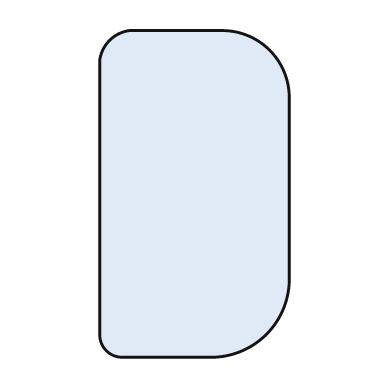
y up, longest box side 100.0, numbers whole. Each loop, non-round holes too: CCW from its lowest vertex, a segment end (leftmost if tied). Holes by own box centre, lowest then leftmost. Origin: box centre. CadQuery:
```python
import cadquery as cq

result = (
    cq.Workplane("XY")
    .moveTo(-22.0, -50.0)
    .lineTo(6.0, -50.0)
    .threePointArc((22.0, -43.0), (29.0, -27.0))
    .lineTo(29.0, 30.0)
    .threePointArc((23.0, 44.0), (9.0, 50.0))
    .lineTo(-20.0, 50.0)
    .threePointArc((-26.0, 47.0), (-29.0, 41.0))
    .lineTo(-29.0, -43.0)
    .threePointArc((-27.0, -48.0), (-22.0, -50.0))
    .close()
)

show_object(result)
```